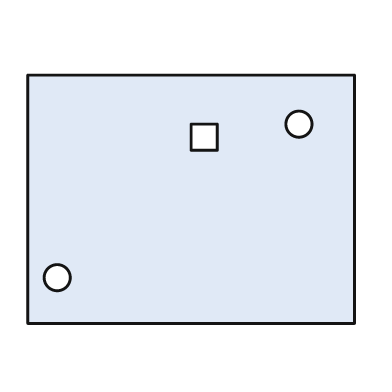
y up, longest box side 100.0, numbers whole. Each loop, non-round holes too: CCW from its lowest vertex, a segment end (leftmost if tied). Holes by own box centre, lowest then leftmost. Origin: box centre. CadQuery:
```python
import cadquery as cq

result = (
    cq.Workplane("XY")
    .moveTo(-50.0, -38.0)
    .lineTo(50.0, -38.0)
    .lineTo(50.0, 38.0)
    .lineTo(-50.0, 38.0)
    .close()
    .moveTo(-41.0, -24.0)
    .circle(4.0)
    .moveTo(0.0, 15.0)
    .lineTo(8.0, 15.0)
    .lineTo(8.0, 23.0)
    .lineTo(0.0, 23.0)
    .close()
    .moveTo(33.0, 23.0)
    .circle(4.0)
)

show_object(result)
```